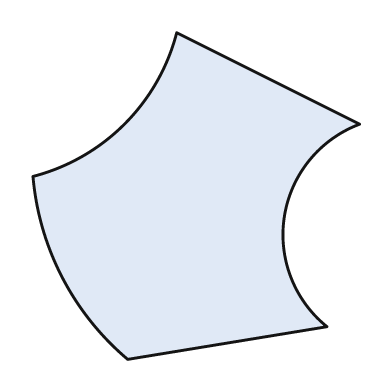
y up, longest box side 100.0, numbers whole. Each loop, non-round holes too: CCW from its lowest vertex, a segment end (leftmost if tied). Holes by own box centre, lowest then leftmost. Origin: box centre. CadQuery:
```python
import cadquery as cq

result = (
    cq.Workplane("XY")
    .moveTo(-21.0, -50.0)
    .lineTo(40.0, -40.0)
    .threePointArc((27.0, -6.0), (50.0, 22.0))
    .lineTo(-6.0, 50.0)
    .threePointArc((-22.0, 22.0), (-50.0, 6.0))
    .threePointArc((-41.0, -25.0), (-21.0, -50.0))
    .close()
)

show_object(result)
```